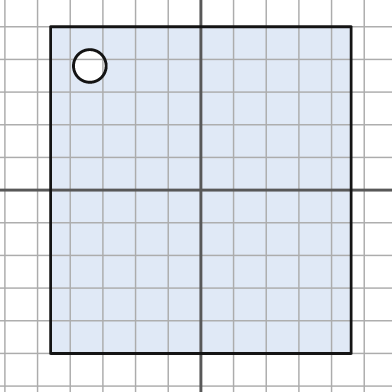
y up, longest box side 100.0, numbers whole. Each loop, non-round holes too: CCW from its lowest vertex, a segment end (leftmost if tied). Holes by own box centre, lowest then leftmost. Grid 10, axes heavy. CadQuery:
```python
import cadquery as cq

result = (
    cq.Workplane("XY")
    .moveTo(-46.0, -50.0)
    .lineTo(46.0, -50.0)
    .lineTo(46.0, 50.0)
    .lineTo(-46.0, 50.0)
    .close()
    .moveTo(-34.0, 38.0)
    .circle(5.0)
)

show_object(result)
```